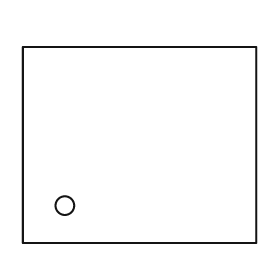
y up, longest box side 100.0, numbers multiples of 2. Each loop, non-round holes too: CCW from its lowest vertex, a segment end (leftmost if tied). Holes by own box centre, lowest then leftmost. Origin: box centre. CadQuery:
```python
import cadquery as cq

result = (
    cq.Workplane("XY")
    .moveTo(-50.0, -42.0)
    .lineTo(50.0, -42.0)
    .lineTo(50.0, 42.0)
    .lineTo(-50.0, 42.0)
    .close()
    .moveTo(-32.0, -26.0)
    .circle(4.0)
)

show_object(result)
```